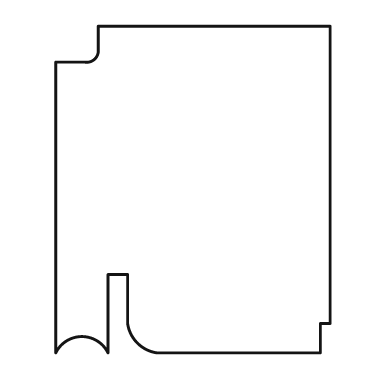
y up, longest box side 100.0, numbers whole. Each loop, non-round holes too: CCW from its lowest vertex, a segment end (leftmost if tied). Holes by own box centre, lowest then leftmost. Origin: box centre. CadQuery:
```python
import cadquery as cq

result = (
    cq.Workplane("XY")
    .moveTo(-42.0, -50.0)
    .threePointArc((-34.0, -45.0), (-26.0, -50.0))
    .lineTo(-26.0, -26.0)
    .lineTo(-20.0, -26.0)
    .lineTo(-20.0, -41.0)
    .threePointArc((-17.0, -47.0), (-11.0, -50.0))
    .lineTo(39.0, -50.0)
    .lineTo(39.0, -41.0)
    .lineTo(42.0, -41.0)
    .lineTo(42.0, 50.0)
    .lineTo(-29.0, 50.0)
    .lineTo(-29.0, 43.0)
    .threePointArc((-30.0, 40.0), (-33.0, 39.0))
    .lineTo(-42.0, 39.0)
    .close()
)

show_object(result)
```